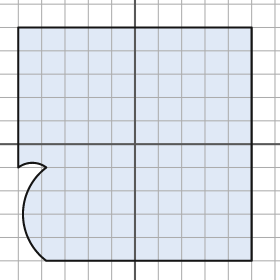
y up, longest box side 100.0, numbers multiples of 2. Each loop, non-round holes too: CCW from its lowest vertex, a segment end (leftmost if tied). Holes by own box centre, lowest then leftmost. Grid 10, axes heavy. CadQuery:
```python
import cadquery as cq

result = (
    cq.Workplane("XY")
    .moveTo(-38.0, -50.0)
    .lineTo(50.0, -50.0)
    .lineTo(50.0, 50.0)
    .lineTo(-50.0, 50.0)
    .lineTo(-50.0, -10.0)
    .threePointArc((-44.0, -8.0), (-38.0, -10.0))
    .threePointArc((-48.0, -30.0), (-38.0, -50.0))
    .close()
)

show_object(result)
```